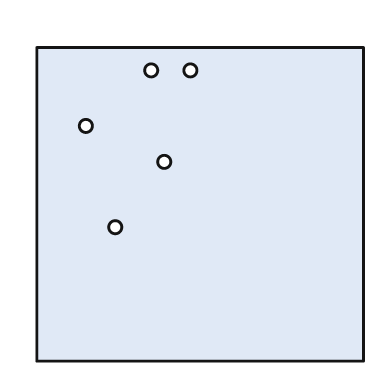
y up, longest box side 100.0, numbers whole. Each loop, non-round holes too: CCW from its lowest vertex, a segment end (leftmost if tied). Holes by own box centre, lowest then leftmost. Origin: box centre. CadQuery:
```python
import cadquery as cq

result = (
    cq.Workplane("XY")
    .moveTo(-50.0, -48.0)
    .lineTo(50.0, -48.0)
    .lineTo(50.0, 48.0)
    .lineTo(-50.0, 48.0)
    .close()
    .moveTo(-26.0, -7.0)
    .circle(2.0)
    .moveTo(-11.0, 13.0)
    .circle(2.0)
    .moveTo(-35.0, 24.0)
    .circle(2.0)
    .moveTo(-15.0, 41.0)
    .circle(2.0)
    .moveTo(-3.0, 41.0)
    .circle(2.0)
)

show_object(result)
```